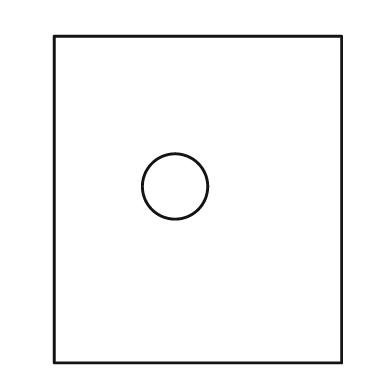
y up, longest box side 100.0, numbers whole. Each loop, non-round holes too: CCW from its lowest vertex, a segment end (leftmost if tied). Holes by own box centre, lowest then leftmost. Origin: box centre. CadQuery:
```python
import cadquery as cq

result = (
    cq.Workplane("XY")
    .moveTo(-44.0, -50.0)
    .lineTo(44.0, -50.0)
    .lineTo(44.0, 50.0)
    .lineTo(-44.0, 50.0)
    .close()
    .moveTo(-7.0, 4.0)
    .circle(10.0)
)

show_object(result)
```